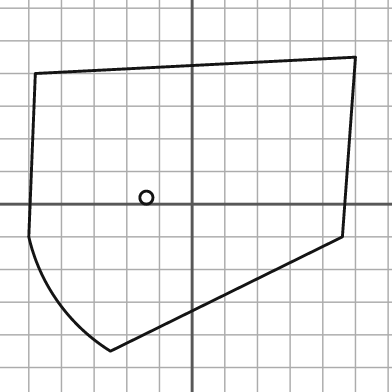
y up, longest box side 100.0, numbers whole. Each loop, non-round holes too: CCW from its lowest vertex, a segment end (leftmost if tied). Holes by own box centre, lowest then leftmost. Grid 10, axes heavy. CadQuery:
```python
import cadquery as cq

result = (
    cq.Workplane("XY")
    .moveTo(-25.0, -45.0)
    .lineTo(46.0, -10.0)
    .lineTo(50.0, 45.0)
    .lineTo(-48.0, 40.0)
    .lineTo(-50.0, -10.0)
    .threePointArc((-41.0, -30.0), (-25.0, -45.0))
    .close()
    .moveTo(-14.0, 2.0)
    .circle(2.0)
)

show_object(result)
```